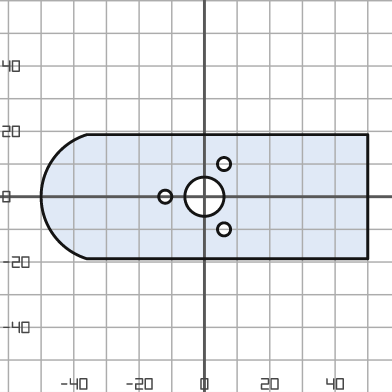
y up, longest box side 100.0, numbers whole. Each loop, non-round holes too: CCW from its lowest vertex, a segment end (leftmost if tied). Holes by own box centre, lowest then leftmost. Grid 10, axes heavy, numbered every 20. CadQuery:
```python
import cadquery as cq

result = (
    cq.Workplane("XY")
    .moveTo(-36.0, -19.0)
    .lineTo(50.0, -19.0)
    .lineTo(50.0, 19.0)
    .lineTo(-36.0, 19.0)
    .threePointArc((-50.0, 0.0), (-36.0, -19.0))
    .close()
    .moveTo(6.0, -10.0)
    .circle(2.0)
    .moveTo(-12.0, 0.0)
    .circle(2.0)
    .moveTo(0.0, 0.0)
    .circle(6.0)
    .moveTo(6.0, 10.0)
    .circle(2.0)
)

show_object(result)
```